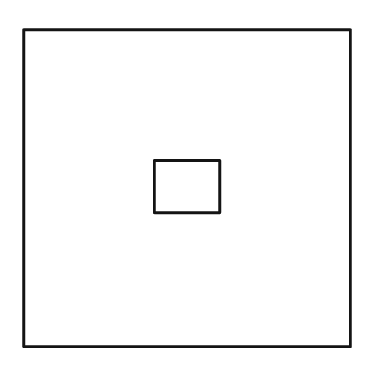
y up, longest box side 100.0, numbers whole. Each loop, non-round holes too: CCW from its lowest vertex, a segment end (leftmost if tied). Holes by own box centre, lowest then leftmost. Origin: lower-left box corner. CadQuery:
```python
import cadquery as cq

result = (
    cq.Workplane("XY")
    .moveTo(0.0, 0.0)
    .lineTo(100.0, 0.0)
    .lineTo(100.0, 97.0)
    .lineTo(0.0, 97.0)
    .close()
    .moveTo(40.0, 41.0)
    .lineTo(60.0, 41.0)
    .lineTo(60.0, 57.0)
    .lineTo(40.0, 57.0)
    .close()
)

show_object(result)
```